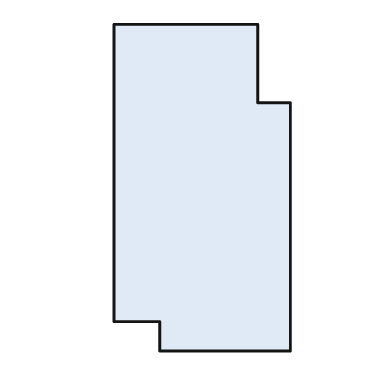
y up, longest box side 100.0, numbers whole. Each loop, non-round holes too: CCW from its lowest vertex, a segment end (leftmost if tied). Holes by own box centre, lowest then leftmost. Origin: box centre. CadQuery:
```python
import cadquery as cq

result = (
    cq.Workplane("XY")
    .moveTo(-13.0, -50.0)
    .lineTo(27.0, -50.0)
    .lineTo(27.0, 26.0)
    .lineTo(17.0, 26.0)
    .lineTo(17.0, 50.0)
    .lineTo(-27.0, 50.0)
    .lineTo(-27.0, -41.0)
    .lineTo(-13.0, -41.0)
    .close()
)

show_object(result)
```